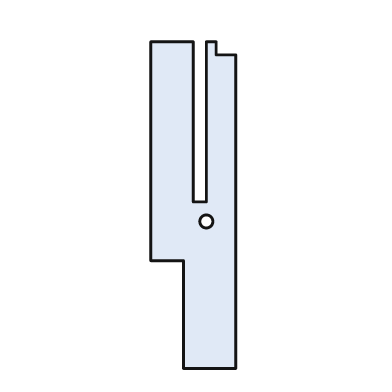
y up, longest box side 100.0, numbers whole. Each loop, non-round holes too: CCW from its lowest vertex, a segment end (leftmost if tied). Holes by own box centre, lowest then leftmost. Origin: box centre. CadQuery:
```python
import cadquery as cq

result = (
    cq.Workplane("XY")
    .moveTo(-3.0, -50.0)
    .lineTo(13.0, -50.0)
    .lineTo(13.0, 46.0)
    .lineTo(7.0, 46.0)
    .lineTo(7.0, 50.0)
    .lineTo(4.0, 50.0)
    .lineTo(4.0, 1.0)
    .lineTo(0.0, 1.0)
    .lineTo(0.0, 50.0)
    .lineTo(-13.0, 50.0)
    .lineTo(-13.0, -17.0)
    .lineTo(-3.0, -17.0)
    .close()
    .moveTo(4.0, -5.0)
    .circle(2.0)
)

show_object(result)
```